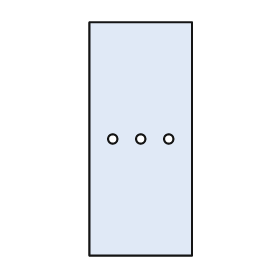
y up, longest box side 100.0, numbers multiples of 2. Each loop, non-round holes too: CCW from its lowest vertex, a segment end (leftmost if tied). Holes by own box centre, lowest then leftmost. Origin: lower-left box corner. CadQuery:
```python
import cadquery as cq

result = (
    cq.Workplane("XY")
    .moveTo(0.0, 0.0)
    .lineTo(44.0, 0.0)
    .lineTo(44.0, 100.0)
    .lineTo(0.0, 100.0)
    .close()
    .moveTo(10.0, 50.0)
    .circle(2.0)
    .moveTo(22.0, 50.0)
    .circle(2.0)
    .moveTo(34.0, 50.0)
    .circle(2.0)
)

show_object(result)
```